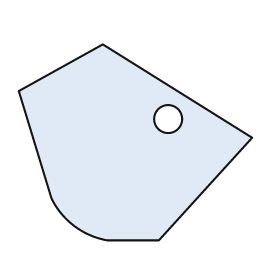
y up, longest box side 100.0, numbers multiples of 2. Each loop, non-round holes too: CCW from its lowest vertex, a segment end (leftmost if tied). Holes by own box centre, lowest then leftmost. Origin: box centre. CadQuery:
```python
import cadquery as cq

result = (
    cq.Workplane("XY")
    .moveTo(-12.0, -42.0)
    .lineTo(10.0, -42.0)
    .lineTo(50.0, 2.0)
    .lineTo(-14.0, 42.0)
    .lineTo(-50.0, 22.0)
    .lineTo(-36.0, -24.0)
    .threePointArc((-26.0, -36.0), (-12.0, -42.0))
    .close()
    .moveTo(14.0, 10.0)
    .circle(6.0)
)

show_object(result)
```